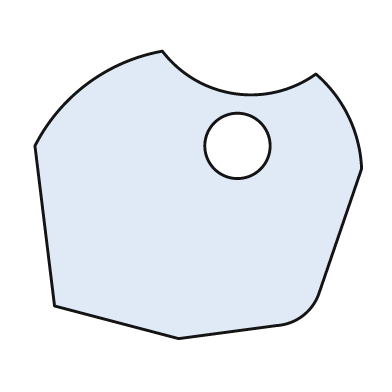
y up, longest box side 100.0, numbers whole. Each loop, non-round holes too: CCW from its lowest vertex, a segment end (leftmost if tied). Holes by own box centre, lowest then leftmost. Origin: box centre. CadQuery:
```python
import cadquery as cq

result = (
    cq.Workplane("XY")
    .moveTo(-6.0, -44.0)
    .lineTo(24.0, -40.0)
    .threePointArc((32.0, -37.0), (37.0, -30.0))
    .lineTo(50.0, 8.0)
    .threePointArc((46.0, 24.0), (36.0, 37.0))
    .threePointArc((11.0, 31.0), (-11.0, 44.0))
    .threePointArc((-34.0, 34.0), (-50.0, 15.0))
    .lineTo(-44.0, -34.0)
    .close()
    .moveTo(12.0, 15.0)
    .circle(10.0)
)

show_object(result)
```